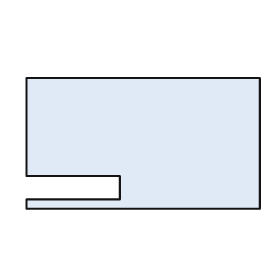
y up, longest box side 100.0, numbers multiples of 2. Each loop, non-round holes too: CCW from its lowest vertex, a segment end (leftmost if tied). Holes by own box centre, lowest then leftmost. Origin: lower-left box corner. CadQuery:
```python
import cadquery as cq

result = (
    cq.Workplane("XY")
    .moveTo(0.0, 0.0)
    .lineTo(100.0, 0.0)
    .lineTo(100.0, 56.0)
    .lineTo(0.0, 56.0)
    .lineTo(0.0, 14.0)
    .lineTo(40.0, 14.0)
    .lineTo(40.0, 4.0)
    .lineTo(0.0, 4.0)
    .close()
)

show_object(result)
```